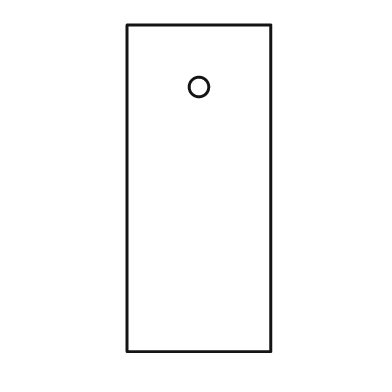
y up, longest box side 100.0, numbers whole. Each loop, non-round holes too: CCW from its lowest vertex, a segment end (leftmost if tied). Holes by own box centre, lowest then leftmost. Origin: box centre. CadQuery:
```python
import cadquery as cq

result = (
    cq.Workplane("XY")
    .moveTo(-22.0, -50.0)
    .lineTo(22.0, -50.0)
    .lineTo(22.0, 50.0)
    .lineTo(-22.0, 50.0)
    .close()
    .moveTo(0.0, 31.0)
    .circle(3.0)
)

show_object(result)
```